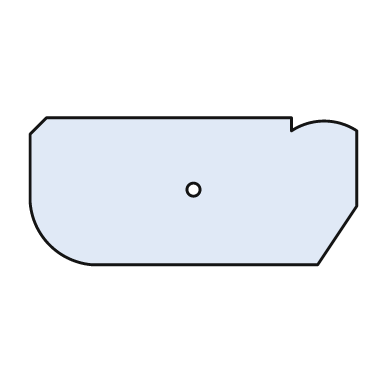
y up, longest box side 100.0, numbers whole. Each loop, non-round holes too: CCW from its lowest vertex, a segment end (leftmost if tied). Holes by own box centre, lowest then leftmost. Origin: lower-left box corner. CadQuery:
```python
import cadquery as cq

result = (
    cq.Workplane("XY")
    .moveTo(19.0, 0.0)
    .lineTo(88.0, 0.0)
    .lineTo(100.0, 18.0)
    .lineTo(100.0, 41.0)
    .threePointArc((90.0, 44.0), (80.0, 41.0))
    .lineTo(80.0, 45.0)
    .lineTo(5.0, 45.0)
    .lineTo(0.0, 40.0)
    .lineTo(0.0, 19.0)
    .threePointArc((6.0, 6.0), (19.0, 0.0))
    .close()
    .moveTo(50.0, 23.0)
    .circle(2.0)
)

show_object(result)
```